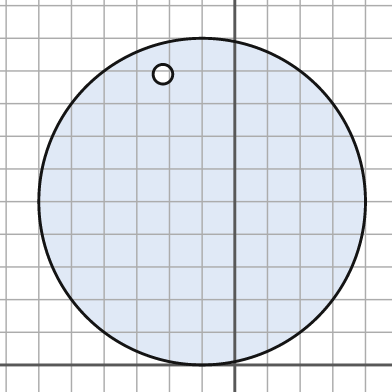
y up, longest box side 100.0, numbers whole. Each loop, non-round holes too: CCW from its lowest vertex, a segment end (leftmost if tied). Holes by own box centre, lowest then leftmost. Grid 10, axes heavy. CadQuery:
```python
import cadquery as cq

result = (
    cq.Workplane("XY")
    .moveTo(-10.0, 50.0)
    .circle(50.0)
    .moveTo(-22.0, 89.0)
    .circle(3.0)
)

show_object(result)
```